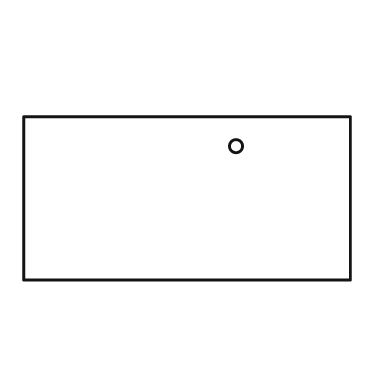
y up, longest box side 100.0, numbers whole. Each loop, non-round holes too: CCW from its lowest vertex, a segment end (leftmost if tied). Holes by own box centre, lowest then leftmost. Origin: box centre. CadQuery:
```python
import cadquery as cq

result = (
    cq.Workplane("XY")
    .moveTo(-50.0, -25.0)
    .lineTo(50.0, -25.0)
    .lineTo(50.0, 25.0)
    .lineTo(-50.0, 25.0)
    .close()
    .moveTo(15.0, 16.0)
    .circle(2.0)
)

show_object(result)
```